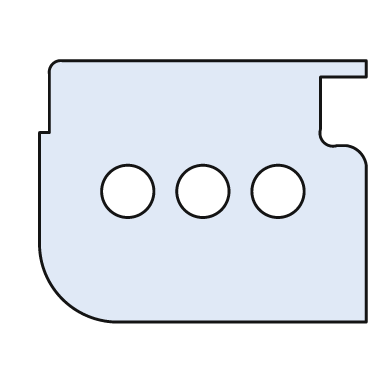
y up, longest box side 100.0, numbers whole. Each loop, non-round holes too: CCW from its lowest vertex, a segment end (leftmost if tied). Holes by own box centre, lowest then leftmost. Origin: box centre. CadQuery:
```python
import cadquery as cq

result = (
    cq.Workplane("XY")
    .moveTo(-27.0, -40.0)
    .lineTo(50.0, -40.0)
    .lineTo(50.0, 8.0)
    .threePointArc((48.0, 12.0), (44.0, 14.0))
    .lineTo(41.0, 14.0)
    .threePointArc((37.0, 15.0), (36.0, 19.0))
    .lineTo(36.0, 35.0)
    .lineTo(50.0, 35.0)
    .lineTo(50.0, 40.0)
    .lineTo(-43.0, 40.0)
    .threePointArc((-46.0, 39.0), (-47.0, 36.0))
    .lineTo(-47.0, 18.0)
    .lineTo(-50.0, 18.0)
    .lineTo(-50.0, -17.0)
    .threePointArc((-43.0, -33.0), (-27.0, -40.0))
    .close()
    .moveTo(-23.0, 0.0)
    .circle(8.0)
    .moveTo(0.0, 0.0)
    .circle(8.0)
    .moveTo(23.0, 0.0)
    .circle(8.0)
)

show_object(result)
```